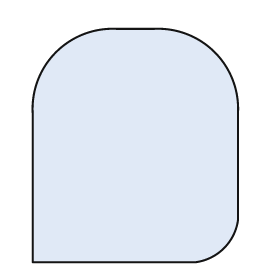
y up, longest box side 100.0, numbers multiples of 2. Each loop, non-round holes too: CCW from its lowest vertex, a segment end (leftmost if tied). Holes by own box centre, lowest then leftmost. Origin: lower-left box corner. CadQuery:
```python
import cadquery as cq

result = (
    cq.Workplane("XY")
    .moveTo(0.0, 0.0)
    .lineTo(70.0, 0.0)
    .threePointArc((82.0, 6.0), (88.0, 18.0))
    .lineTo(88.0, 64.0)
    .threePointArc((78.0, 90.0), (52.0, 100.0))
    .lineTo(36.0, 100.0)
    .threePointArc((10.0, 90.0), (0.0, 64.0))
    .close()
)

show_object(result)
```